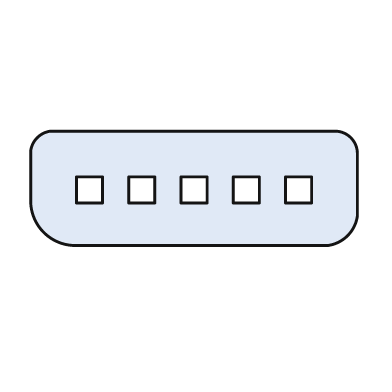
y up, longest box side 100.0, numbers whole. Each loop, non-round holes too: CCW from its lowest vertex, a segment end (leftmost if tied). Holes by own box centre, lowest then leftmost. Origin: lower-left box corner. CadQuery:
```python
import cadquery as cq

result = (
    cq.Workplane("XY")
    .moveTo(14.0, 0.0)
    .lineTo(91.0, 0.0)
    .threePointArc((97.0, 3.0), (100.0, 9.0))
    .lineTo(100.0, 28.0)
    .threePointArc((98.0, 33.0), (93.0, 35.0))
    .lineTo(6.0, 35.0)
    .threePointArc((2.0, 33.0), (0.0, 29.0))
    .lineTo(0.0, 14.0)
    .threePointArc((4.0, 4.0), (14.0, 0.0))
    .close()
    .moveTo(14.0, 13.0)
    .lineTo(22.0, 13.0)
    .lineTo(22.0, 21.0)
    .lineTo(14.0, 21.0)
    .close()
    .moveTo(30.0, 13.0)
    .lineTo(38.0, 13.0)
    .lineTo(38.0, 21.0)
    .lineTo(30.0, 21.0)
    .close()
    .moveTo(46.0, 13.0)
    .lineTo(54.0, 13.0)
    .lineTo(54.0, 21.0)
    .lineTo(46.0, 21.0)
    .close()
    .moveTo(62.0, 13.0)
    .lineTo(70.0, 13.0)
    .lineTo(70.0, 21.0)
    .lineTo(62.0, 21.0)
    .close()
    .moveTo(78.0, 13.0)
    .lineTo(86.0, 13.0)
    .lineTo(86.0, 21.0)
    .lineTo(78.0, 21.0)
    .close()
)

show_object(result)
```